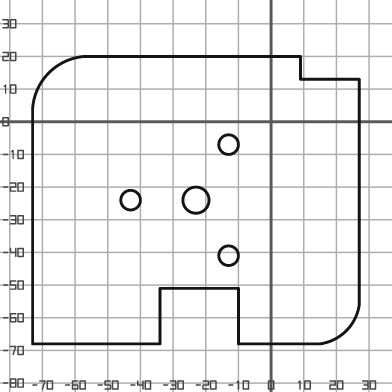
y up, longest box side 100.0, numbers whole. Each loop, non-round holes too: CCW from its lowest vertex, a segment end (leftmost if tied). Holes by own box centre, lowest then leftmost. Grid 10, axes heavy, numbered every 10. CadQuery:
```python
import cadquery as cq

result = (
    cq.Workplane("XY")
    .moveTo(-73.0, -68.0)
    .lineTo(-34.0, -68.0)
    .lineTo(-34.0, -51.0)
    .lineTo(-10.0, -51.0)
    .lineTo(-10.0, -68.0)
    .lineTo(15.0, -68.0)
    .threePointArc((23.0, -64.0), (27.0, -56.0))
    .lineTo(27.0, 13.0)
    .lineTo(9.0, 13.0)
    .lineTo(9.0, 20.0)
    .lineTo(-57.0, 20.0)
    .threePointArc((-68.0, 15.0), (-73.0, 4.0))
    .close()
    .moveTo(-13.0, -41.0)
    .circle(3.0)
    .moveTo(-43.0, -24.0)
    .circle(3.0)
    .moveTo(-23.0, -24.0)
    .circle(4.0)
    .moveTo(-13.0, -7.0)
    .circle(3.0)
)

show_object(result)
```